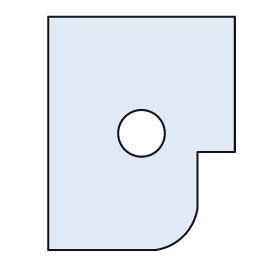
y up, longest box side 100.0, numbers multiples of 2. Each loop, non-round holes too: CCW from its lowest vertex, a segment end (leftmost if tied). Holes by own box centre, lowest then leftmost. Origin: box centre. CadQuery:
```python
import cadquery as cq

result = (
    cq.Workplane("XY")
    .moveTo(-40.0, -50.0)
    .lineTo(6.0, -50.0)
    .threePointArc((18.0, -44.0), (24.0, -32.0))
    .lineTo(24.0, -8.0)
    .lineTo(40.0, -8.0)
    .lineTo(40.0, 50.0)
    .lineTo(-40.0, 50.0)
    .close()
    .moveTo(0.0, 0.0)
    .circle(10.0)
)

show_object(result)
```